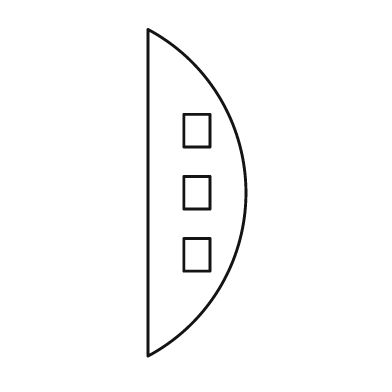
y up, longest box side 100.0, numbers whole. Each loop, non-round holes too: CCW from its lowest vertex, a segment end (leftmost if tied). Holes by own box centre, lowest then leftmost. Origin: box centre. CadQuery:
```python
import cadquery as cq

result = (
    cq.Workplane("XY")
    .moveTo(-15.0, -50.0)
    .threePointArc((15.0, 0.0), (-15.0, 50.0))
    .close()
    .moveTo(-4.0, -24.0)
    .lineTo(4.0, -24.0)
    .lineTo(4.0, -14.0)
    .lineTo(-4.0, -14.0)
    .close()
    .moveTo(-4.0, -5.0)
    .lineTo(4.0, -5.0)
    .lineTo(4.0, 5.0)
    .lineTo(-4.0, 5.0)
    .close()
    .moveTo(-4.0, 14.0)
    .lineTo(4.0, 14.0)
    .lineTo(4.0, 24.0)
    .lineTo(-4.0, 24.0)
    .close()
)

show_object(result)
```